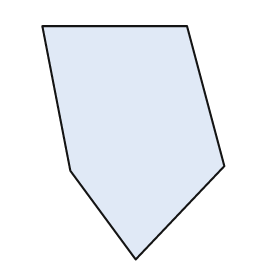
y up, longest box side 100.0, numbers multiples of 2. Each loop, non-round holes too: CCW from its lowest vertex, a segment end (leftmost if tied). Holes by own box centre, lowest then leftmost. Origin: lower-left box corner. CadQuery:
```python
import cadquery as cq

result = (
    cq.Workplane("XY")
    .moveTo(40.0, 0.0)
    .lineTo(78.0, 40.0)
    .lineTo(62.0, 100.0)
    .lineTo(0.0, 100.0)
    .lineTo(12.0, 38.0)
    .close()
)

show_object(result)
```